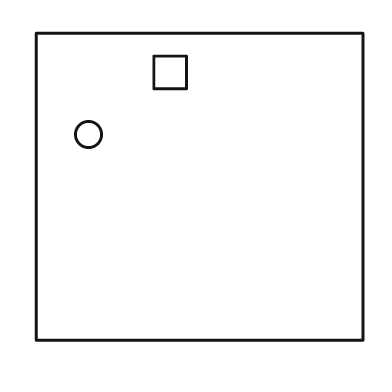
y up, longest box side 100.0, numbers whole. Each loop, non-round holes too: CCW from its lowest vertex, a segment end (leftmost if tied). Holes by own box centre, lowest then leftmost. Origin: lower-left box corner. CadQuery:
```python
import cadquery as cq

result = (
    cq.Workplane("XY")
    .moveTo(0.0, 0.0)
    .lineTo(100.0, 0.0)
    .lineTo(100.0, 94.0)
    .lineTo(0.0, 94.0)
    .close()
    .moveTo(16.0, 63.0)
    .circle(4.0)
    .moveTo(36.0, 77.0)
    .lineTo(46.0, 77.0)
    .lineTo(46.0, 87.0)
    .lineTo(36.0, 87.0)
    .close()
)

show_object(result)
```